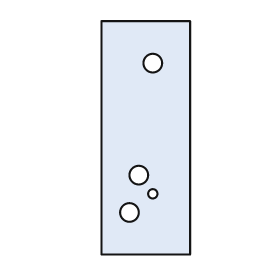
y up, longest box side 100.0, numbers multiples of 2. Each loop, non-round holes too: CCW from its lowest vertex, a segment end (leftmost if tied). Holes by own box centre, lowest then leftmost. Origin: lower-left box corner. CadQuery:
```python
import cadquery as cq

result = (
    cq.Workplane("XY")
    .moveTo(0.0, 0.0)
    .lineTo(38.0, 0.0)
    .lineTo(38.0, 100.0)
    .lineTo(0.0, 100.0)
    .close()
    .moveTo(12.0, 18.0)
    .circle(4.0)
    .moveTo(22.0, 26.0)
    .circle(2.0)
    .moveTo(16.0, 34.0)
    .circle(4.0)
    .moveTo(22.0, 82.0)
    .circle(4.0)
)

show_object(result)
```